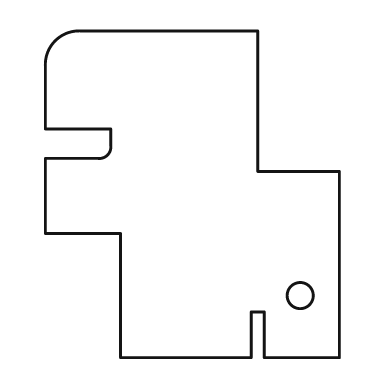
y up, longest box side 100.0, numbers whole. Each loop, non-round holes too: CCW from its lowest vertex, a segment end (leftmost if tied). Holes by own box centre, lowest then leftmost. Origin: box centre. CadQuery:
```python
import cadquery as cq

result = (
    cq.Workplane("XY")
    .moveTo(-22.0, -50.0)
    .lineTo(18.0, -50.0)
    .lineTo(18.0, -36.0)
    .lineTo(22.0, -36.0)
    .lineTo(22.0, -50.0)
    .lineTo(45.0, -50.0)
    .lineTo(45.0, 7.0)
    .lineTo(20.0, 7.0)
    .lineTo(20.0, 50.0)
    .lineTo(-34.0, 50.0)
    .threePointArc((-42.0, 47.0), (-45.0, 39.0))
    .lineTo(-45.0, 20.0)
    .lineTo(-25.0, 20.0)
    .lineTo(-25.0, 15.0)
    .threePointArc((-26.0, 12.0), (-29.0, 11.0))
    .lineTo(-45.0, 11.0)
    .lineTo(-45.0, -12.0)
    .lineTo(-22.0, -12.0)
    .close()
    .moveTo(33.0, -31.0)
    .circle(4.0)
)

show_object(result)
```